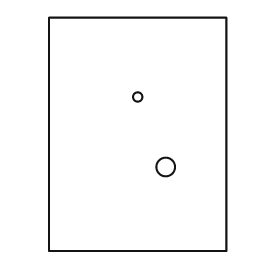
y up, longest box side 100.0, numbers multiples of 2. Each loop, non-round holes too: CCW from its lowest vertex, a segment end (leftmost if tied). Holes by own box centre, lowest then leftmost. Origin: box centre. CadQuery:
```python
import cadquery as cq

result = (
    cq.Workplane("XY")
    .moveTo(-38.0, -50.0)
    .lineTo(38.0, -50.0)
    .lineTo(38.0, 50.0)
    .lineTo(-38.0, 50.0)
    .close()
    .moveTo(12.0, -14.0)
    .circle(4.0)
    .moveTo(0.0, 16.0)
    .circle(2.0)
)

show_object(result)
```